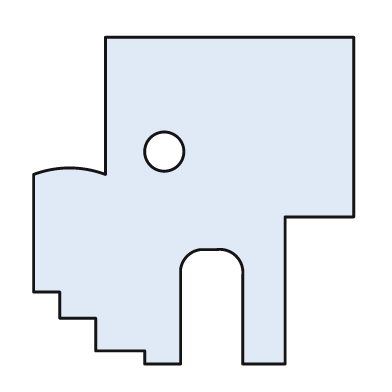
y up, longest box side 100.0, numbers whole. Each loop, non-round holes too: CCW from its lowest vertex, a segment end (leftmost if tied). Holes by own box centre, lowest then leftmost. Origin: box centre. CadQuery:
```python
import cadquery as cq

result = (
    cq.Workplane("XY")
    .moveTo(-15.0, -50.0)
    .lineTo(-4.0, -50.0)
    .lineTo(-4.0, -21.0)
    .threePointArc((-2.0, -17.0), (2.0, -15.0))
    .lineTo(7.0, -15.0)
    .threePointArc((13.0, -17.0), (15.0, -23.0))
    .lineTo(15.0, -50.0)
    .lineTo(28.0, -50.0)
    .lineTo(28.0, -5.0)
    .lineTo(49.0, -5.0)
    .lineTo(49.0, 50.0)
    .lineTo(-27.0, 50.0)
    .lineTo(-27.0, 8.0)
    .threePointArc((-38.0, 10.0), (-49.0, 8.0))
    .lineTo(-49.0, -28.0)
    .lineTo(-41.0, -28.0)
    .lineTo(-41.0, -36.0)
    .lineTo(-30.0, -36.0)
    .lineTo(-30.0, -46.0)
    .lineTo(-15.0, -46.0)
    .close()
    .moveTo(-9.0, 15.0)
    .circle(6.0)
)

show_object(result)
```